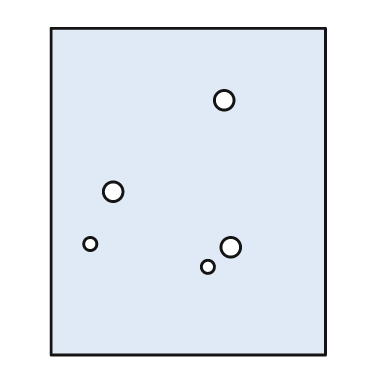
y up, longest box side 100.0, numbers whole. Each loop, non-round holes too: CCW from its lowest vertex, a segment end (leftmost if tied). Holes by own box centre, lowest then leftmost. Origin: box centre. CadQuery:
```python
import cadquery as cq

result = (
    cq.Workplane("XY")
    .moveTo(-42.0, -50.0)
    .lineTo(42.0, -50.0)
    .lineTo(42.0, 50.0)
    .lineTo(-42.0, 50.0)
    .close()
    .moveTo(6.0, -23.0)
    .circle(2.0)
    .moveTo(13.0, -17.0)
    .circle(3.0)
    .moveTo(-30.0, -16.0)
    .circle(2.0)
    .moveTo(-23.0, 0.0)
    .circle(3.0)
    .moveTo(11.0, 28.0)
    .circle(3.0)
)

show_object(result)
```